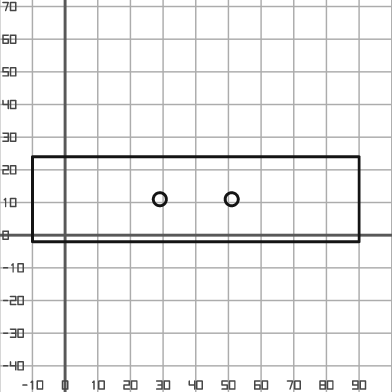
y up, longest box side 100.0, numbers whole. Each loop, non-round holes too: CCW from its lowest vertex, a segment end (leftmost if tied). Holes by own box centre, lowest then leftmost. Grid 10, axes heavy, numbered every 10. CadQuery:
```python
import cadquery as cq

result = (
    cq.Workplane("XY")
    .moveTo(-10.0, -2.0)
    .lineTo(90.0, -2.0)
    .lineTo(90.0, 24.0)
    .lineTo(-10.0, 24.0)
    .close()
    .moveTo(29.0, 11.0)
    .circle(2.0)
    .moveTo(51.0, 11.0)
    .circle(2.0)
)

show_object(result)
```